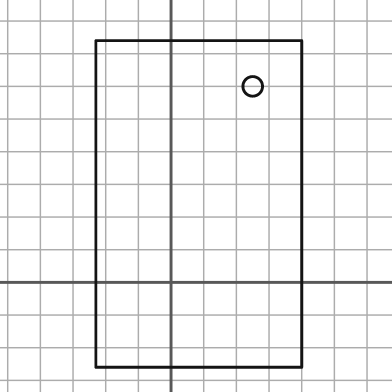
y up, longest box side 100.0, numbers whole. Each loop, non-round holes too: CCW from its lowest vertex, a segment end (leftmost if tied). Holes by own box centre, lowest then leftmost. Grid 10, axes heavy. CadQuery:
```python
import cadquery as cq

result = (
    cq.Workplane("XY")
    .moveTo(-23.0, -26.0)
    .lineTo(40.0, -26.0)
    .lineTo(40.0, 74.0)
    .lineTo(-23.0, 74.0)
    .close()
    .moveTo(25.0, 60.0)
    .circle(3.0)
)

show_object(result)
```